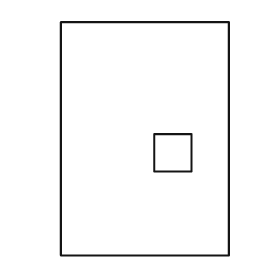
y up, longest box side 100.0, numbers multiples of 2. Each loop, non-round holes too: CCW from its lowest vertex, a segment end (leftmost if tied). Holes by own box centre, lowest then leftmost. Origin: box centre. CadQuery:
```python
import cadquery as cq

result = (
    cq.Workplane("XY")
    .moveTo(-36.0, -50.0)
    .lineTo(36.0, -50.0)
    .lineTo(36.0, 50.0)
    .lineTo(-36.0, 50.0)
    .close()
    .moveTo(4.0, -14.0)
    .lineTo(20.0, -14.0)
    .lineTo(20.0, 2.0)
    .lineTo(4.0, 2.0)
    .close()
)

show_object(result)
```